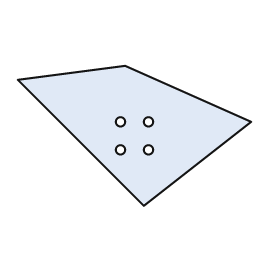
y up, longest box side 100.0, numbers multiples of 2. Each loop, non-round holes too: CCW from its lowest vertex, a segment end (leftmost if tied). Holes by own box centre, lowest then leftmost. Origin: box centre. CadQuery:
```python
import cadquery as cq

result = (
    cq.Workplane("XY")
    .moveTo(4.0, -30.0)
    .lineTo(50.0, 6.0)
    .lineTo(-4.0, 30.0)
    .lineTo(-50.0, 24.0)
    .close()
    .moveTo(-6.0, -6.0)
    .circle(2.0)
    .moveTo(6.0, -6.0)
    .circle(2.0)
    .moveTo(-6.0, 6.0)
    .circle(2.0)
    .moveTo(6.0, 6.0)
    .circle(2.0)
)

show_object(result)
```